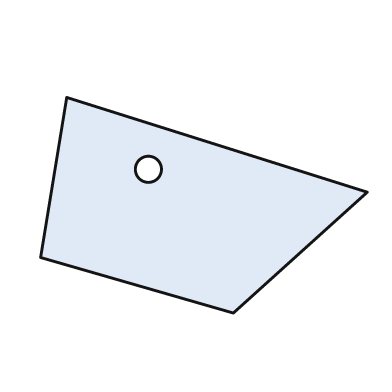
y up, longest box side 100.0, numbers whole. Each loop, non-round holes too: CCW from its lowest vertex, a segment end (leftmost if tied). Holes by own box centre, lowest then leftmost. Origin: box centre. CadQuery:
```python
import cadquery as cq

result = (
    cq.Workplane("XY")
    .moveTo(9.0, -33.0)
    .lineTo(50.0, 4.0)
    .lineTo(-42.0, 33.0)
    .lineTo(-50.0, -16.0)
    .close()
    .moveTo(-17.0, 11.0)
    .circle(4.0)
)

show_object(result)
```